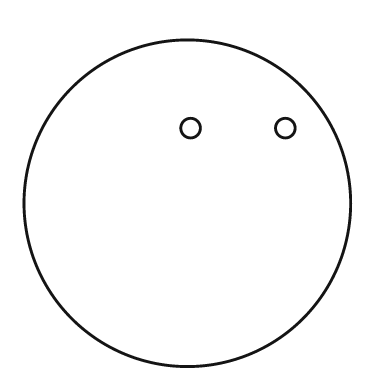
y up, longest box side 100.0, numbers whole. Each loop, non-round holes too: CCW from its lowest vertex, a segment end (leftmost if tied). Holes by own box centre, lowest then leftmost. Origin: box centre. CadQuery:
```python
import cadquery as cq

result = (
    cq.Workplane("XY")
    .moveTo(0.0, 0.0)
    .circle(50.0)
    .moveTo(1.0, 23.0)
    .circle(3.0)
    .moveTo(30.0, 23.0)
    .circle(3.0)
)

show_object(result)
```